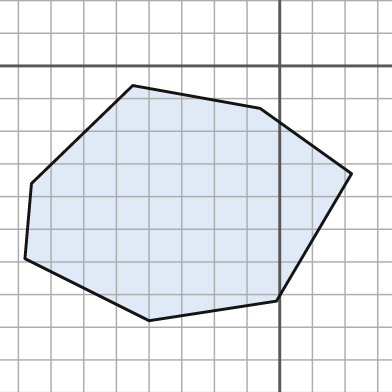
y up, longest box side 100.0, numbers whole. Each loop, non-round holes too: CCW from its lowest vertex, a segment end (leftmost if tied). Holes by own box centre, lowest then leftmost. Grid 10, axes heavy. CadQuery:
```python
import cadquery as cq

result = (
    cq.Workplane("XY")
    .moveTo(-40.0, -78.0)
    .lineTo(-1.0, -72.0)
    .lineTo(22.0, -33.0)
    .lineTo(-6.0, -13.0)
    .lineTo(-45.0, -6.0)
    .lineTo(-76.0, -36.0)
    .lineTo(-78.0, -59.0)
    .close()
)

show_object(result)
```